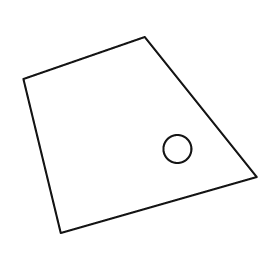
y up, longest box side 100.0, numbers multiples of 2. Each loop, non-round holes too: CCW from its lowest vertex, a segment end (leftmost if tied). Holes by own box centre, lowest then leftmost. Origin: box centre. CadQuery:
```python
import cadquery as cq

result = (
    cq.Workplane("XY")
    .moveTo(-34.0, -42.0)
    .lineTo(50.0, -18.0)
    .lineTo(2.0, 42.0)
    .lineTo(-50.0, 24.0)
    .close()
    .moveTo(16.0, -6.0)
    .circle(6.0)
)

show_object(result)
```